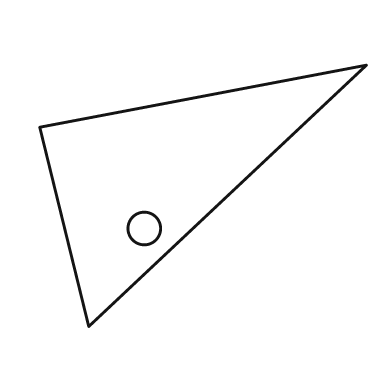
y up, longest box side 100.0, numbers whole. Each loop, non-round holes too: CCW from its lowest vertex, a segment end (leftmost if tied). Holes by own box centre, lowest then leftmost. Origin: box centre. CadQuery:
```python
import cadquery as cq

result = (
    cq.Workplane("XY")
    .moveTo(-35.0, -40.0)
    .lineTo(50.0, 40.0)
    .lineTo(-50.0, 21.0)
    .close()
    .moveTo(-18.0, -10.0)
    .circle(5.0)
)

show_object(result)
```